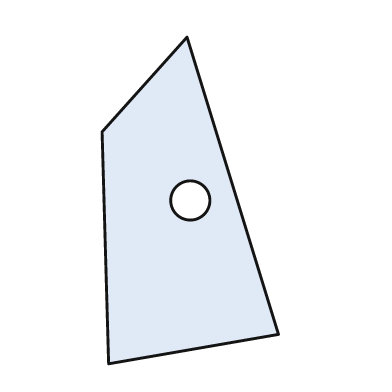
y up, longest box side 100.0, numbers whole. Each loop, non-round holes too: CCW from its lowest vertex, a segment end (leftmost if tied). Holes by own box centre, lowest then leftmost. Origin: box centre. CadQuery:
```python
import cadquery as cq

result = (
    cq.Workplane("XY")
    .moveTo(-25.0, -50.0)
    .lineTo(27.0, -41.0)
    .lineTo(-1.0, 50.0)
    .lineTo(-27.0, 21.0)
    .close()
    .moveTo(0.0, 0.0)
    .circle(6.0)
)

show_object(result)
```